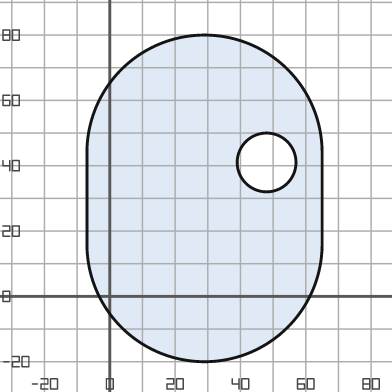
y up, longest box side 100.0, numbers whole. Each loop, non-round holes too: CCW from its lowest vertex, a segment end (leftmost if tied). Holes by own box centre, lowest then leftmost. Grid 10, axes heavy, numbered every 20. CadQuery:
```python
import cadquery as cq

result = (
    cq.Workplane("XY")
    .moveTo(-7.0, 16.0)
    .threePointArc((29.0, -20.0), (65.0, 16.0))
    .lineTo(65.0, 44.0)
    .threePointArc((29.0, 80.0), (-7.0, 44.0))
    .close()
    .moveTo(48.0, 41.0)
    .circle(9.0)
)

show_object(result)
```